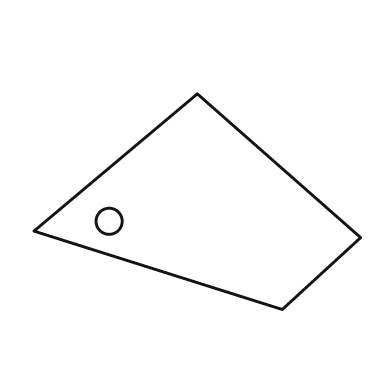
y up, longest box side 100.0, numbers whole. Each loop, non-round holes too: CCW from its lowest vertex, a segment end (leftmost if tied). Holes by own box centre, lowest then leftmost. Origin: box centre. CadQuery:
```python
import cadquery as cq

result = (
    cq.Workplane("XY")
    .moveTo(26.0, -33.0)
    .lineTo(50.0, -11.0)
    .lineTo(0.0, 33.0)
    .lineTo(-50.0, -9.0)
    .close()
    .moveTo(-27.0, -6.0)
    .circle(4.0)
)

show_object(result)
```